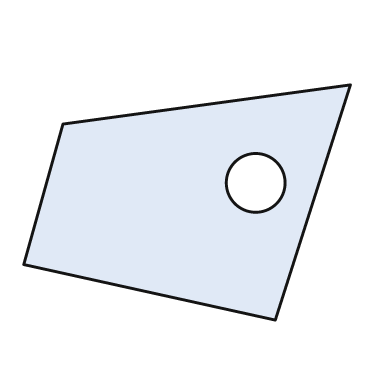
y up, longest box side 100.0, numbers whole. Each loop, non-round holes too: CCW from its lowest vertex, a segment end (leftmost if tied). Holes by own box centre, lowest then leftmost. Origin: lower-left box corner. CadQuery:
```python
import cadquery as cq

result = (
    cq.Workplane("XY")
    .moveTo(77.0, 0.0)
    .lineTo(100.0, 72.0)
    .lineTo(12.0, 60.0)
    .lineTo(0.0, 17.0)
    .close()
    .moveTo(71.0, 42.0)
    .circle(9.0)
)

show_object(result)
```